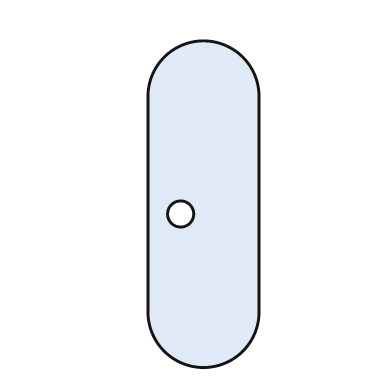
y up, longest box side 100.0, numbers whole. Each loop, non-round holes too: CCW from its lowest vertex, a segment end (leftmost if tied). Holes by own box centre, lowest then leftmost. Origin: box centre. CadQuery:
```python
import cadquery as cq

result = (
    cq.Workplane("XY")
    .moveTo(-17.0, -33.0)
    .threePointArc((0.0, -50.0), (17.0, -33.0))
    .lineTo(17.0, 33.0)
    .threePointArc((0.0, 50.0), (-17.0, 33.0))
    .close()
    .moveTo(-7.0, -3.0)
    .circle(4.0)
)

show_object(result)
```